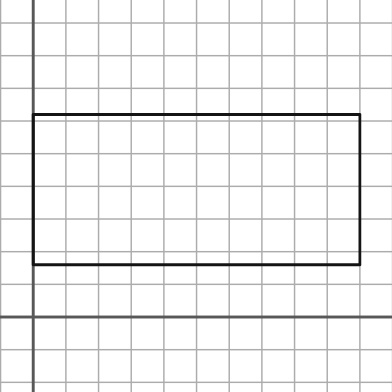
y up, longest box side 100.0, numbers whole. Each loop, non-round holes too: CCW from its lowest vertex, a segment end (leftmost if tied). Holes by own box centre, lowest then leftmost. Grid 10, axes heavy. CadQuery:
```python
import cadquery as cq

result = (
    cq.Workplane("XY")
    .moveTo(0.0, 16.0)
    .lineTo(100.0, 16.0)
    .lineTo(100.0, 62.0)
    .lineTo(0.0, 62.0)
    .close()
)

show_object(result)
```